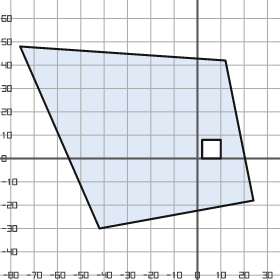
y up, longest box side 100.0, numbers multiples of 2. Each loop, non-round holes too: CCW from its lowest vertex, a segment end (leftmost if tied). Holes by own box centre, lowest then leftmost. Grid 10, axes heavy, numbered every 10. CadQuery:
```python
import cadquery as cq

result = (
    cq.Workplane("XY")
    .moveTo(-42.0, -30.0)
    .lineTo(24.0, -18.0)
    .lineTo(12.0, 42.0)
    .lineTo(-76.0, 48.0)
    .close()
    .moveTo(2.0, 0.0)
    .lineTo(10.0, 0.0)
    .lineTo(10.0, 8.0)
    .lineTo(2.0, 8.0)
    .close()
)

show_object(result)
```